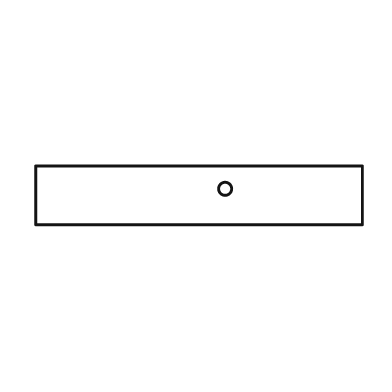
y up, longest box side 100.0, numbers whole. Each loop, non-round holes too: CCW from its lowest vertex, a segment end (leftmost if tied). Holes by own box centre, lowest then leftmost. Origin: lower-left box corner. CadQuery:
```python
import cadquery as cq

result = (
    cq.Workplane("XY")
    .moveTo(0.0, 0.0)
    .lineTo(100.0, 0.0)
    .lineTo(100.0, 18.0)
    .lineTo(0.0, 18.0)
    .close()
    .moveTo(58.0, 11.0)
    .circle(2.0)
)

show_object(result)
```